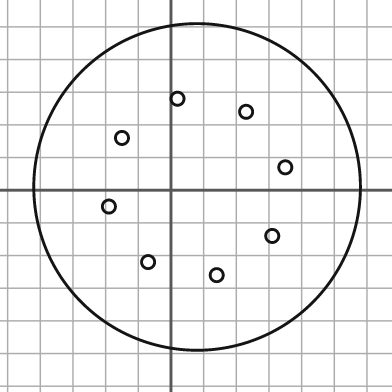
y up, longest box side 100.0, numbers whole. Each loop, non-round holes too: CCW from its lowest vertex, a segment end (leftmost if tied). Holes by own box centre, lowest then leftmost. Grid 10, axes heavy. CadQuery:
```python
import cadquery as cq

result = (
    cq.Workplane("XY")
    .moveTo(8.0, 1.0)
    .circle(50.0)
    .moveTo(14.0, -26.0)
    .circle(2.0)
    .moveTo(-7.0, -22.0)
    .circle(2.0)
    .moveTo(31.0, -14.0)
    .circle(2.0)
    .moveTo(-19.0, -5.0)
    .circle(2.0)
    .moveTo(35.0, 7.0)
    .circle(2.0)
    .moveTo(-15.0, 16.0)
    .circle(2.0)
    .moveTo(23.0, 24.0)
    .circle(2.0)
    .moveTo(2.0, 28.0)
    .circle(2.0)
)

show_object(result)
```